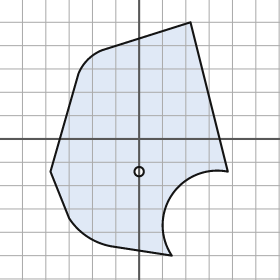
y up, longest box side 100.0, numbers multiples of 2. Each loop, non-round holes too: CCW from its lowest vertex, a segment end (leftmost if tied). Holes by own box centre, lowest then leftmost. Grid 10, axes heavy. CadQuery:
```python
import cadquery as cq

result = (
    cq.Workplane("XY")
    .moveTo(14.0, -50.0)
    .threePointArc((14.0, -24.0), (38.0, -14.0))
    .lineTo(22.0, 50.0)
    .lineTo(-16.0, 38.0)
    .threePointArc((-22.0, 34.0), (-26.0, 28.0))
    .lineTo(-38.0, -14.0)
    .lineTo(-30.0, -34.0)
    .threePointArc((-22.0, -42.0), (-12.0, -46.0))
    .close()
    .moveTo(0.0, -14.0)
    .circle(2.0)
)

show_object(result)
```